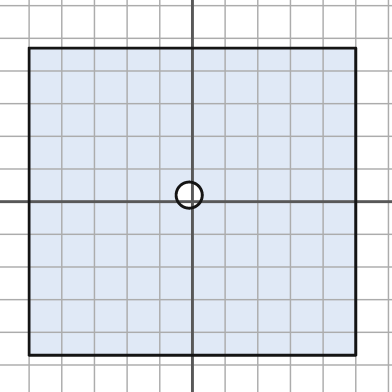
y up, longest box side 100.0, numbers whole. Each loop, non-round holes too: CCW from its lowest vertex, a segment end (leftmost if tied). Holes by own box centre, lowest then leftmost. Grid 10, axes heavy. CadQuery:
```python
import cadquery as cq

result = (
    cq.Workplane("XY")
    .moveTo(-50.0, -47.0)
    .lineTo(50.0, -47.0)
    .lineTo(50.0, 47.0)
    .lineTo(-50.0, 47.0)
    .close()
    .moveTo(-1.0, 2.0)
    .circle(4.0)
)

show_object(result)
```